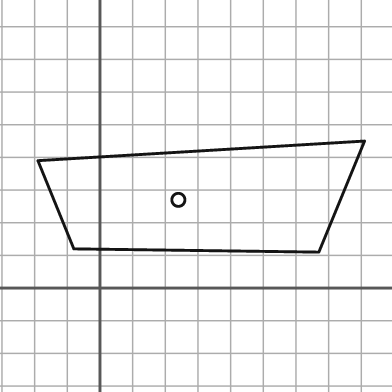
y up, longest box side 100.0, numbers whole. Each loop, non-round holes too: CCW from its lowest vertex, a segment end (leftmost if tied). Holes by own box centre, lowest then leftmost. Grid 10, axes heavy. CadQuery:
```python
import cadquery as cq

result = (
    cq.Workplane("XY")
    .moveTo(67.0, 11.0)
    .lineTo(81.0, 45.0)
    .lineTo(-19.0, 39.0)
    .lineTo(-8.0, 12.0)
    .close()
    .moveTo(24.0, 27.0)
    .circle(2.0)
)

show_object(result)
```